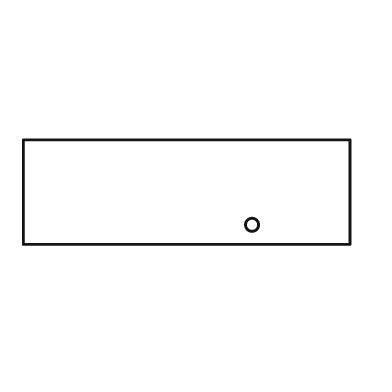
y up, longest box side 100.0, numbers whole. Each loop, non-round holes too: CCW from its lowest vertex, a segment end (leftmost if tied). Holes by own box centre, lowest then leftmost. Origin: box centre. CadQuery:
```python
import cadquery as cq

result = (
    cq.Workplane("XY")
    .moveTo(-50.0, -16.0)
    .lineTo(50.0, -16.0)
    .lineTo(50.0, 16.0)
    .lineTo(-50.0, 16.0)
    .close()
    .moveTo(20.0, -10.0)
    .circle(2.0)
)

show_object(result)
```